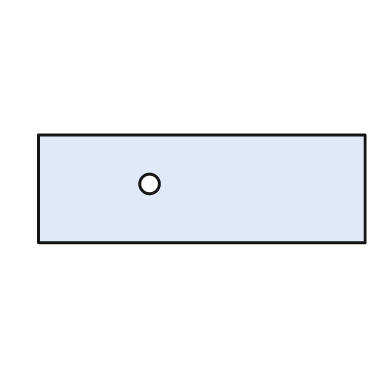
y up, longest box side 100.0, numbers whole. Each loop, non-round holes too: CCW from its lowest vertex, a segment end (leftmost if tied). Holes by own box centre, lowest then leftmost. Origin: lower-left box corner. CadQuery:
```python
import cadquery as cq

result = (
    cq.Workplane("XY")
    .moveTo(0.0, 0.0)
    .lineTo(100.0, 0.0)
    .lineTo(100.0, 33.0)
    .lineTo(0.0, 33.0)
    .close()
    .moveTo(34.0, 18.0)
    .circle(3.0)
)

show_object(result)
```